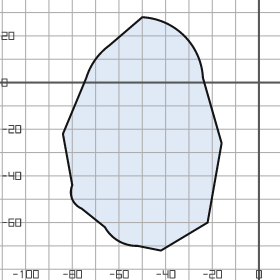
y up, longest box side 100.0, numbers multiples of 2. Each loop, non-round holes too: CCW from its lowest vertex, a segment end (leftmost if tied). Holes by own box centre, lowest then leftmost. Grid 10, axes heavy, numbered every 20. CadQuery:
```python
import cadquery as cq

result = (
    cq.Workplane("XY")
    .moveTo(-42.0, -72.0)
    .lineTo(-22.0, -60.0)
    .lineTo(-16.0, -26.0)
    .lineTo(-24.0, 2.0)
    .threePointArc((-32.0, 20.0), (-50.0, 28.0))
    .lineTo(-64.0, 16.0)
    .threePointArc((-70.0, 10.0), (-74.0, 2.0))
    .lineTo(-84.0, -22.0)
    .lineTo(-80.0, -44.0)
    .threePointArc((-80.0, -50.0), (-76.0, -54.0))
    .lineTo(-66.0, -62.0)
    .threePointArc((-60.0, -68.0), (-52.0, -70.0))
    .close()
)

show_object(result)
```